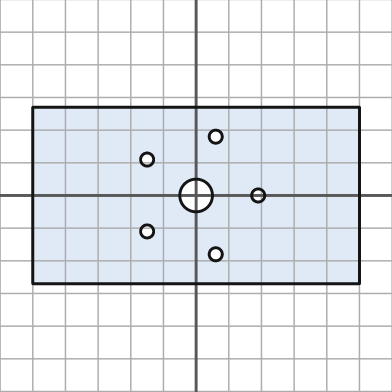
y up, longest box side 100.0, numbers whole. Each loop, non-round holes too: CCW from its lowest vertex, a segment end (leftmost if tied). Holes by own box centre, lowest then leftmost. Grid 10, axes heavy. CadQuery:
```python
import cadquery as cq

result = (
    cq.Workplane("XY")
    .moveTo(-50.0, -27.0)
    .lineTo(50.0, -27.0)
    .lineTo(50.0, 27.0)
    .lineTo(-50.0, 27.0)
    .close()
    .moveTo(6.0, -18.0)
    .circle(2.0)
    .moveTo(-15.0, -11.0)
    .circle(2.0)
    .moveTo(0.0, 0.0)
    .circle(5.0)
    .moveTo(19.0, 0.0)
    .circle(2.0)
    .moveTo(-15.0, 11.0)
    .circle(2.0)
    .moveTo(6.0, 18.0)
    .circle(2.0)
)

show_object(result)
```